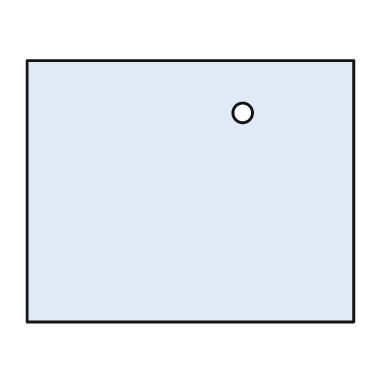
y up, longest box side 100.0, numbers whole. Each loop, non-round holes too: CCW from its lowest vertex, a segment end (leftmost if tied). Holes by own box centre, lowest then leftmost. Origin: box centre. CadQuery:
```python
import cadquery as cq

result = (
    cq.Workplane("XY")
    .moveTo(-50.0, -40.0)
    .lineTo(50.0, -40.0)
    .lineTo(50.0, 40.0)
    .lineTo(-50.0, 40.0)
    .close()
    .moveTo(16.0, 24.0)
    .circle(3.0)
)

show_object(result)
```